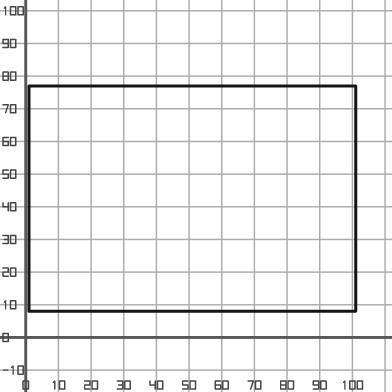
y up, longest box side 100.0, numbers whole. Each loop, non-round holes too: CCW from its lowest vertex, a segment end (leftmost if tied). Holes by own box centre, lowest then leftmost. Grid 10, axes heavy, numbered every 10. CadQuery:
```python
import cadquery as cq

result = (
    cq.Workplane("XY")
    .moveTo(1.0, 8.0)
    .lineTo(101.0, 8.0)
    .lineTo(101.0, 77.0)
    .lineTo(1.0, 77.0)
    .close()
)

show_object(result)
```